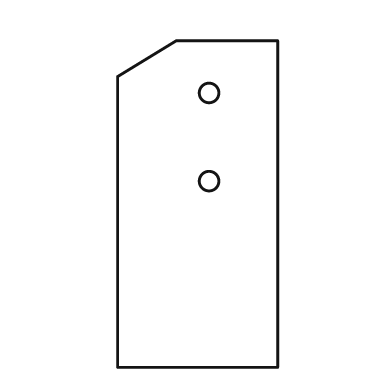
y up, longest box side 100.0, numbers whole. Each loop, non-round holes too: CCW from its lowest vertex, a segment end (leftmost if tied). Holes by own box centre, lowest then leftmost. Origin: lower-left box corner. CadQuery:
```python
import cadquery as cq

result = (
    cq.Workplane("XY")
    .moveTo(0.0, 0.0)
    .lineTo(49.0, 0.0)
    .lineTo(49.0, 100.0)
    .lineTo(18.0, 100.0)
    .lineTo(0.0, 89.0)
    .close()
    .moveTo(28.0, 57.0)
    .circle(3.0)
    .moveTo(28.0, 84.0)
    .circle(3.0)
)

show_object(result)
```